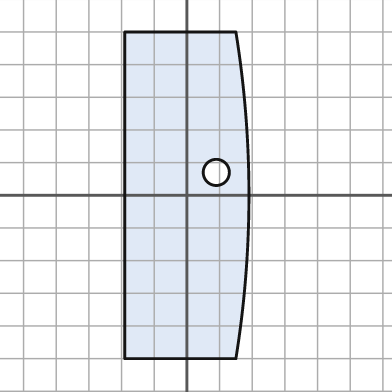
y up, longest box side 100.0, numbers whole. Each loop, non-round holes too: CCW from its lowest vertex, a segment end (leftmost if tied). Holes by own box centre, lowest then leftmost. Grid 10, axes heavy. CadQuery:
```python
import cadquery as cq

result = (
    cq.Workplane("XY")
    .moveTo(-19.0, -50.0)
    .lineTo(15.0, -50.0)
    .threePointArc((19.0, 0.0), (15.0, 50.0))
    .lineTo(-19.0, 50.0)
    .close()
    .moveTo(9.0, 7.0)
    .circle(4.0)
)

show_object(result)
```